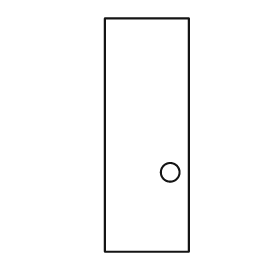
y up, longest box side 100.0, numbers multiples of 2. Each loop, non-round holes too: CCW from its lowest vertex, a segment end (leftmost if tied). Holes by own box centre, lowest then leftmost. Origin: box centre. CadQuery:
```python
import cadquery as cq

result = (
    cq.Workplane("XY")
    .moveTo(-18.0, -50.0)
    .lineTo(18.0, -50.0)
    .lineTo(18.0, 50.0)
    .lineTo(-18.0, 50.0)
    .close()
    .moveTo(10.0, -16.0)
    .circle(4.0)
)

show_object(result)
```